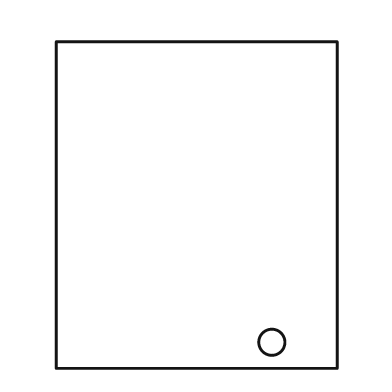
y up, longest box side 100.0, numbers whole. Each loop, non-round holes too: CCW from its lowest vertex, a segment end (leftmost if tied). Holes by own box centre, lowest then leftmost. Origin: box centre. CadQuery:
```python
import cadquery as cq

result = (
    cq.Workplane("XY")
    .moveTo(-43.0, -50.0)
    .lineTo(43.0, -50.0)
    .lineTo(43.0, 50.0)
    .lineTo(-43.0, 50.0)
    .close()
    .moveTo(23.0, -42.0)
    .circle(4.0)
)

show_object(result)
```